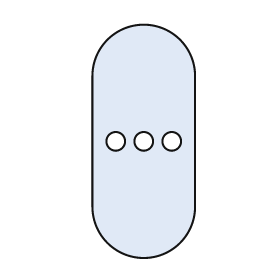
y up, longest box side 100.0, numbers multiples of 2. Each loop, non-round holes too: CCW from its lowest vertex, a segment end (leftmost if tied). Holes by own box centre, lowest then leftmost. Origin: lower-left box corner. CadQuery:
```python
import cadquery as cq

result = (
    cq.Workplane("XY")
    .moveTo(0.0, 22.0)
    .threePointArc((22.0, 0.0), (44.0, 22.0))
    .lineTo(44.0, 78.0)
    .threePointArc((22.0, 100.0), (0.0, 78.0))
    .close()
    .moveTo(10.0, 50.0)
    .circle(4.0)
    .moveTo(22.0, 50.0)
    .circle(4.0)
    .moveTo(34.0, 50.0)
    .circle(4.0)
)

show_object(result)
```